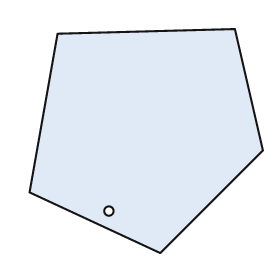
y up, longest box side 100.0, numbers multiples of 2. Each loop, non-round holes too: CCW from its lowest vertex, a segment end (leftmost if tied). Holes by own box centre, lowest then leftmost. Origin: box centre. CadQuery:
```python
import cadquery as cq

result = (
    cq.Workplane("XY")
    .moveTo(6.0, -48.0)
    .lineTo(50.0, -4.0)
    .lineTo(38.0, 48.0)
    .lineTo(-38.0, 46.0)
    .lineTo(-50.0, -22.0)
    .close()
    .moveTo(-16.0, -30.0)
    .circle(2.0)
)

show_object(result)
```